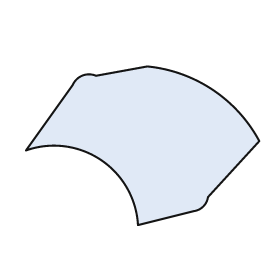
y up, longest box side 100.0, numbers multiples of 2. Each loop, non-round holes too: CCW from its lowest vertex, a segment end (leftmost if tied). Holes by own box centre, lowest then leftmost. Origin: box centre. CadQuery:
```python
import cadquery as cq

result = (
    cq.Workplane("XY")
    .moveTo(-2.0, -34.0)
    .lineTo(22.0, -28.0)
    .threePointArc((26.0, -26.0), (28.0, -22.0))
    .lineTo(50.0, 2.0)
    .threePointArc((30.0, 24.0), (2.0, 34.0))
    .lineTo(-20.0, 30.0)
    .threePointArc((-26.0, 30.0), (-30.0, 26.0))
    .lineTo(-50.0, -2.0)
    .threePointArc((-18.0, -6.0), (-2.0, -34.0))
    .close()
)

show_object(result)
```